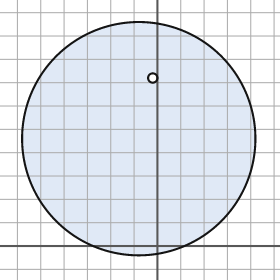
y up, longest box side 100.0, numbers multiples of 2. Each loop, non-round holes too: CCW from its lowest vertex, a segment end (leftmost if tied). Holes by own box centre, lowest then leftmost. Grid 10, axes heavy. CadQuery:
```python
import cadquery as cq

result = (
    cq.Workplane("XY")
    .moveTo(-8.0, 46.0)
    .circle(50.0)
    .moveTo(-2.0, 72.0)
    .circle(2.0)
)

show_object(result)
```